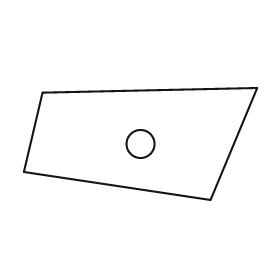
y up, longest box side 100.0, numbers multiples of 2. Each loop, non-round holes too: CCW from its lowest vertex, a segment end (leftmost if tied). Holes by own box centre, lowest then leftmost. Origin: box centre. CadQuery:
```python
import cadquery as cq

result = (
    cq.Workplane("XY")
    .moveTo(30.0, -24.0)
    .lineTo(50.0, 24.0)
    .lineTo(-42.0, 22.0)
    .lineTo(-50.0, -12.0)
    .close()
    .moveTo(0.0, 0.0)
    .circle(6.0)
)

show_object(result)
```